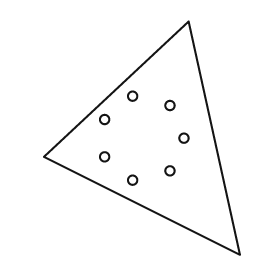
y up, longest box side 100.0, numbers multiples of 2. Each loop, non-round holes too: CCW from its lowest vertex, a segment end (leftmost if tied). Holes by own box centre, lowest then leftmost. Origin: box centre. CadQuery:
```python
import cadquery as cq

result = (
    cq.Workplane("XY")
    .moveTo(42.0, -50.0)
    .lineTo(20.0, 50.0)
    .lineTo(-42.0, -8.0)
    .close()
    .moveTo(-4.0, -18.0)
    .circle(2.0)
    .moveTo(12.0, -14.0)
    .circle(2.0)
    .moveTo(-16.0, -8.0)
    .circle(2.0)
    .moveTo(18.0, 0.0)
    .circle(2.0)
    .moveTo(-16.0, 8.0)
    .circle(2.0)
    .moveTo(12.0, 14.0)
    .circle(2.0)
    .moveTo(-4.0, 18.0)
    .circle(2.0)
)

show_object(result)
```